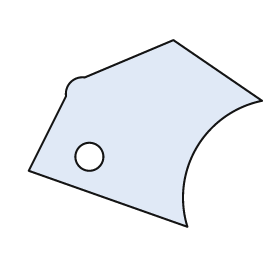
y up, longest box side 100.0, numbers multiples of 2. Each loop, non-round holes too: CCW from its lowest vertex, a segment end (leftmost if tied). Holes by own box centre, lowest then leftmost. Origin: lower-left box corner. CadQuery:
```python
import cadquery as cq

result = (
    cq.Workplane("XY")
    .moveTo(68.0, 0.0)
    .threePointArc((72.0, 34.0), (100.0, 54.0))
    .lineTo(62.0, 80.0)
    .lineTo(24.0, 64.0)
    .threePointArc((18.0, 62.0), (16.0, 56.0))
    .lineTo(0.0, 24.0)
    .close()
    .moveTo(26.0, 30.0)
    .circle(6.0)
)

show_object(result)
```